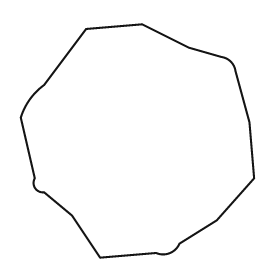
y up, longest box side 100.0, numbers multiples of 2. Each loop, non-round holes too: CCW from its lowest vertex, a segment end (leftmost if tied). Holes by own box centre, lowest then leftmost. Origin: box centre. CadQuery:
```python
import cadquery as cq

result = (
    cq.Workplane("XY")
    .moveTo(-16.0, -50.0)
    .lineTo(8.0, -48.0)
    .threePointArc((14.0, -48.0), (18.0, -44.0))
    .lineTo(34.0, -34.0)
    .lineTo(50.0, -16.0)
    .lineTo(48.0, 8.0)
    .lineTo(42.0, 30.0)
    .threePointArc((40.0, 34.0), (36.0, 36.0))
    .lineTo(22.0, 40.0)
    .lineTo(2.0, 50.0)
    .lineTo(-22.0, 48.0)
    .lineTo(-40.0, 24.0)
    .threePointArc((-46.0, 18.0), (-50.0, 10.0))
    .lineTo(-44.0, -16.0)
    .threePointArc((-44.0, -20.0), (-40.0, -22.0))
    .lineTo(-28.0, -32.0)
    .close()
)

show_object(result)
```